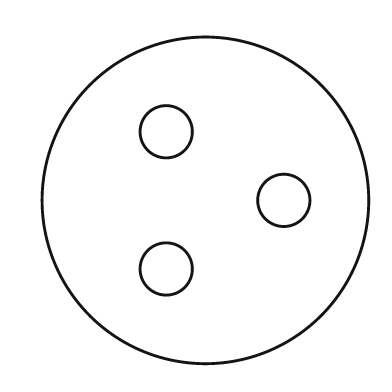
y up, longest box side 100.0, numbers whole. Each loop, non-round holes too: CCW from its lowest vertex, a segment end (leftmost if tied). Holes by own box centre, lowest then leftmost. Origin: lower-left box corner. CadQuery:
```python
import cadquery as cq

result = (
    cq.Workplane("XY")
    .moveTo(50.0, 50.0)
    .circle(50.0)
    .moveTo(38.0, 29.0)
    .circle(8.0)
    .moveTo(74.0, 50.0)
    .circle(8.0)
    .moveTo(38.0, 71.0)
    .circle(8.0)
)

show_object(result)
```